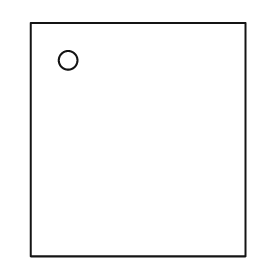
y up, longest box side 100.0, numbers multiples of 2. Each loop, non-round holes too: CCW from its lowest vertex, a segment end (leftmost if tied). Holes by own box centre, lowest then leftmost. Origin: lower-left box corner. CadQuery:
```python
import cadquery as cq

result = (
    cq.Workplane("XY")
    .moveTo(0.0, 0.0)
    .lineTo(92.0, 0.0)
    .lineTo(92.0, 100.0)
    .lineTo(0.0, 100.0)
    .close()
    .moveTo(16.0, 84.0)
    .circle(4.0)
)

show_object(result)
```